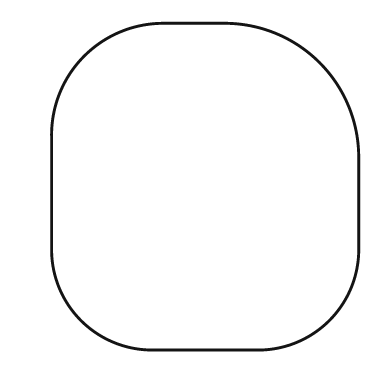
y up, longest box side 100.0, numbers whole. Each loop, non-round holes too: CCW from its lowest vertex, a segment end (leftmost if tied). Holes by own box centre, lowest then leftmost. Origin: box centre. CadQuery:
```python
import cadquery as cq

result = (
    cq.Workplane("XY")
    .moveTo(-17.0, -50.0)
    .lineTo(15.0, -50.0)
    .threePointArc((38.0, -41.0), (47.0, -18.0))
    .lineTo(47.0, 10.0)
    .threePointArc((35.0, 38.0), (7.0, 50.0))
    .lineTo(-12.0, 50.0)
    .threePointArc((-37.0, 40.0), (-47.0, 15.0))
    .lineTo(-47.0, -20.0)
    .threePointArc((-38.0, -41.0), (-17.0, -50.0))
    .close()
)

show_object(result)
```